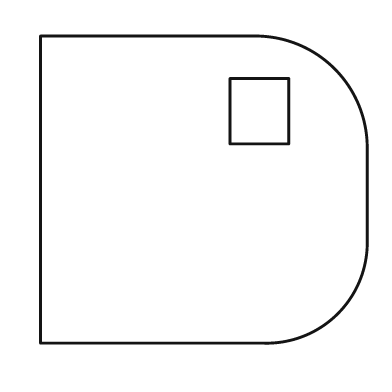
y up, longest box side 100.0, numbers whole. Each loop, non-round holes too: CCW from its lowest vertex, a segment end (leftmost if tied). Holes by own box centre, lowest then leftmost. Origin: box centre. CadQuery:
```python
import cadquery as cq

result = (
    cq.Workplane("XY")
    .moveTo(-50.0, -47.0)
    .lineTo(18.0, -47.0)
    .threePointArc((41.0, -38.0), (50.0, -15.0))
    .lineTo(50.0, 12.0)
    .threePointArc((40.0, 37.0), (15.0, 47.0))
    .lineTo(-50.0, 47.0)
    .close()
    .moveTo(8.0, 14.0)
    .lineTo(26.0, 14.0)
    .lineTo(26.0, 34.0)
    .lineTo(8.0, 34.0)
    .close()
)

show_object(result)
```